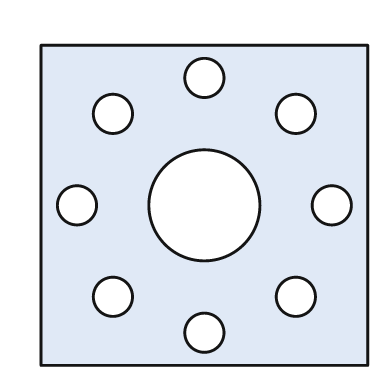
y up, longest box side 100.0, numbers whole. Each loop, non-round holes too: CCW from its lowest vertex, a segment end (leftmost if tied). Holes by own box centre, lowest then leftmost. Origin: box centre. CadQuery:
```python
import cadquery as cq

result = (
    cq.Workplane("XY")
    .moveTo(-50.0, -49.0)
    .lineTo(50.0, -49.0)
    .lineTo(50.0, 49.0)
    .lineTo(-50.0, 49.0)
    .close()
    .moveTo(0.0, -39.0)
    .circle(6.0)
    .moveTo(-28.0, -28.0)
    .circle(6.0)
    .moveTo(28.0, -28.0)
    .circle(6.0)
    .moveTo(-39.0, 0.0)
    .circle(6.0)
    .moveTo(0.0, 0.0)
    .circle(17.0)
    .moveTo(39.0, 0.0)
    .circle(6.0)
    .moveTo(-28.0, 28.0)
    .circle(6.0)
    .moveTo(28.0, 28.0)
    .circle(6.0)
    .moveTo(0.0, 39.0)
    .circle(6.0)
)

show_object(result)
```